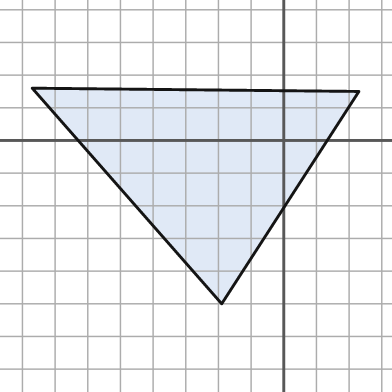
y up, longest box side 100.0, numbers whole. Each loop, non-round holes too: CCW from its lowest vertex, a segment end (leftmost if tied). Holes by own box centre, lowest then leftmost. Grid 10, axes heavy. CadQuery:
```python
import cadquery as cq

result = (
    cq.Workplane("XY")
    .moveTo(-19.0, -50.0)
    .lineTo(23.0, 15.0)
    .lineTo(-77.0, 16.0)
    .close()
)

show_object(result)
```